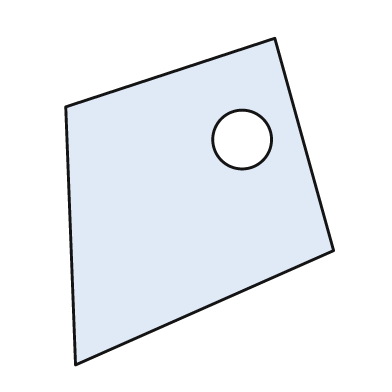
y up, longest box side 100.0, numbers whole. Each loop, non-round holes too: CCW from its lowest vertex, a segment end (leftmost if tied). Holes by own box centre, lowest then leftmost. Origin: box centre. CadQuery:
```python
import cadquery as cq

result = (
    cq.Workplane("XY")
    .moveTo(-38.0, -50.0)
    .lineTo(41.0, -15.0)
    .lineTo(23.0, 50.0)
    .lineTo(-41.0, 29.0)
    .close()
    .moveTo(13.0, 19.0)
    .circle(9.0)
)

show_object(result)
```